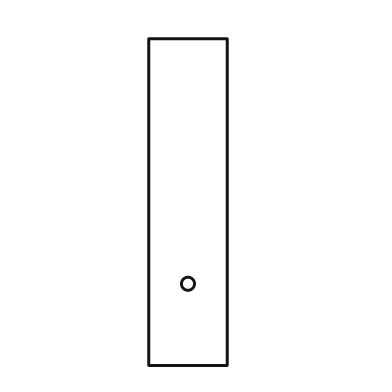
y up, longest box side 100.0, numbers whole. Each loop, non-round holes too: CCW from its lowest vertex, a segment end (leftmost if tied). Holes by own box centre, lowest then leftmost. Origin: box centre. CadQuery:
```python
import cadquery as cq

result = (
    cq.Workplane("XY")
    .moveTo(-12.0, -50.0)
    .lineTo(12.0, -50.0)
    .lineTo(12.0, 50.0)
    .lineTo(-12.0, 50.0)
    .close()
    .moveTo(0.0, -25.0)
    .circle(2.0)
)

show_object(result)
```